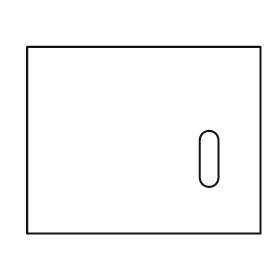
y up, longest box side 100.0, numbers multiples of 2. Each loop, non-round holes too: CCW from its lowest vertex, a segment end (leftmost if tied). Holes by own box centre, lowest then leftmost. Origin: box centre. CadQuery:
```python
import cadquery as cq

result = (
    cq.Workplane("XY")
    .moveTo(-50.0, -40.0)
    .lineTo(50.0, -40.0)
    .lineTo(50.0, 40.0)
    .lineTo(-50.0, 40.0)
    .close()
    .moveTo(24.0, -16.0)
    .threePointArc((28.0, -20.0), (32.0, -16.0))
    .lineTo(32.0, 0.0)
    .threePointArc((28.0, 4.0), (24.0, 0.0))
    .close()
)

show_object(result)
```